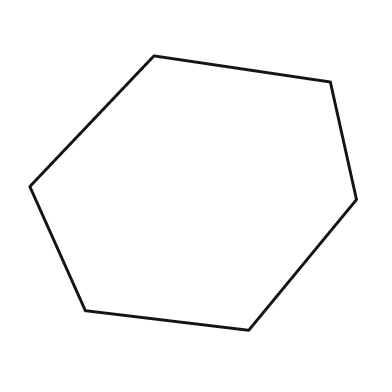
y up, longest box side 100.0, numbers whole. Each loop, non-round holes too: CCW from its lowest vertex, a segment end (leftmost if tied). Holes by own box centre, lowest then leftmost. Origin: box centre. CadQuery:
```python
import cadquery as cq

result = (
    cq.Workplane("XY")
    .moveTo(17.0, -42.0)
    .lineTo(50.0, -2.0)
    .lineTo(42.0, 34.0)
    .lineTo(-12.0, 42.0)
    .lineTo(-50.0, 2.0)
    .lineTo(-33.0, -36.0)
    .close()
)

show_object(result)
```